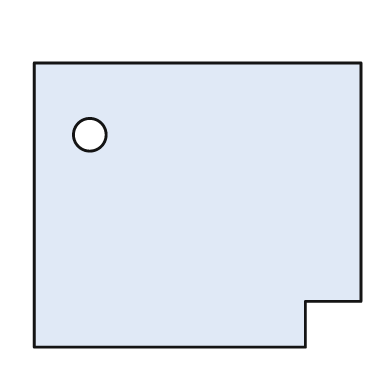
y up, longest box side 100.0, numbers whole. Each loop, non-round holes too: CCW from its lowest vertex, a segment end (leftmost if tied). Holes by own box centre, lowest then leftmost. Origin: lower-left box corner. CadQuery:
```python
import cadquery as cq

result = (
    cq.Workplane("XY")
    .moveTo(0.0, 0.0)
    .lineTo(83.0, 0.0)
    .lineTo(83.0, 14.0)
    .lineTo(100.0, 14.0)
    .lineTo(100.0, 87.0)
    .lineTo(0.0, 87.0)
    .close()
    .moveTo(17.0, 65.0)
    .circle(5.0)
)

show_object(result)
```